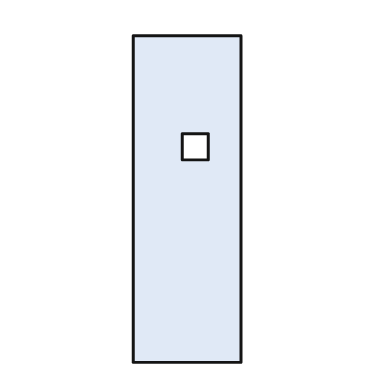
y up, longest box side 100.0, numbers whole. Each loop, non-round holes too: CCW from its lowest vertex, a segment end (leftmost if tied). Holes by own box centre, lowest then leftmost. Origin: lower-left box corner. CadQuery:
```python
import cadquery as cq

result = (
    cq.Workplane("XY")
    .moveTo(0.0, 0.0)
    .lineTo(33.0, 0.0)
    .lineTo(33.0, 100.0)
    .lineTo(0.0, 100.0)
    .close()
    .moveTo(15.0, 62.0)
    .lineTo(23.0, 62.0)
    .lineTo(23.0, 70.0)
    .lineTo(15.0, 70.0)
    .close()
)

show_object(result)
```